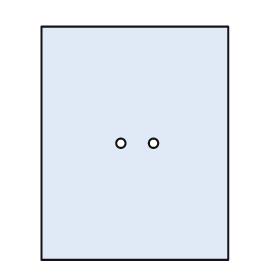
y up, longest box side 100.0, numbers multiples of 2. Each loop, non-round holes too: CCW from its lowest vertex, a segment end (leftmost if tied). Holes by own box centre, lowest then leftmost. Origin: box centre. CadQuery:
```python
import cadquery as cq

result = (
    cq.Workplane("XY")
    .moveTo(-40.0, -50.0)
    .lineTo(40.0, -50.0)
    .lineTo(40.0, 50.0)
    .lineTo(-40.0, 50.0)
    .close()
    .moveTo(-6.0, 0.0)
    .circle(2.0)
    .moveTo(8.0, 0.0)
    .circle(2.0)
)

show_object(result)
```